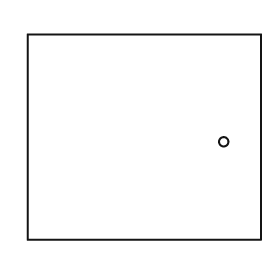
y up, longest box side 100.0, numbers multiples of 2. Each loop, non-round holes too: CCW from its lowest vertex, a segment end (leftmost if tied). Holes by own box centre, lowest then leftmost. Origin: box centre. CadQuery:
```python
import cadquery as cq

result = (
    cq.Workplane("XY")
    .moveTo(-50.0, -44.0)
    .lineTo(50.0, -44.0)
    .lineTo(50.0, 44.0)
    .lineTo(-50.0, 44.0)
    .close()
    .moveTo(34.0, -2.0)
    .circle(2.0)
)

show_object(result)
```